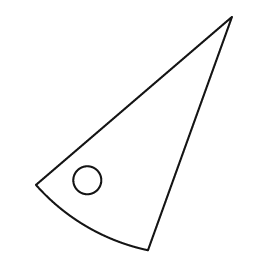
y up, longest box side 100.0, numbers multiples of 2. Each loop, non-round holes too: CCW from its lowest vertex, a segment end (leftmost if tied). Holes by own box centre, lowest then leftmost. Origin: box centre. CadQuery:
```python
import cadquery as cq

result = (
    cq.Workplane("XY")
    .moveTo(6.0, -50.0)
    .lineTo(42.0, 50.0)
    .lineTo(-42.0, -22.0)
    .threePointArc((-20.0, -40.0), (6.0, -50.0))
    .close()
    .moveTo(-20.0, -20.0)
    .circle(6.0)
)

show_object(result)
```